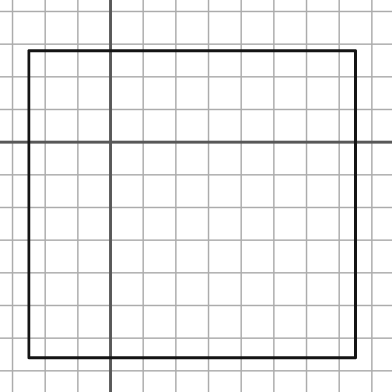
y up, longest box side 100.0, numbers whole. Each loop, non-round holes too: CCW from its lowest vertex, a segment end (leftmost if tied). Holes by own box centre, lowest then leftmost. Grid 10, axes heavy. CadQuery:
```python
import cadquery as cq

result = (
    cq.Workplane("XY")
    .moveTo(-25.0, -66.0)
    .lineTo(75.0, -66.0)
    .lineTo(75.0, 28.0)
    .lineTo(-25.0, 28.0)
    .close()
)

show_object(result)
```